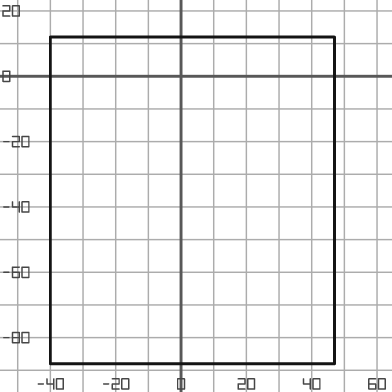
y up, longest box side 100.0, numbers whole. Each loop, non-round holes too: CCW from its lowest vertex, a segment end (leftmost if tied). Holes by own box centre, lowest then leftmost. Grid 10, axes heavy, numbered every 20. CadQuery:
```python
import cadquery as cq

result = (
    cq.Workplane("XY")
    .moveTo(-40.0, -88.0)
    .lineTo(47.0, -88.0)
    .lineTo(47.0, 12.0)
    .lineTo(-40.0, 12.0)
    .close()
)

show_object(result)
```